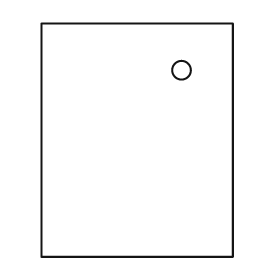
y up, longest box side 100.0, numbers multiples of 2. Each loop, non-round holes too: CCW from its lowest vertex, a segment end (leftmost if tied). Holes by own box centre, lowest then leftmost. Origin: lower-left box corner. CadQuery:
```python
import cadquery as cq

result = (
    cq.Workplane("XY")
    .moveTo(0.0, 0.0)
    .lineTo(82.0, 0.0)
    .lineTo(82.0, 100.0)
    .lineTo(0.0, 100.0)
    .close()
    .moveTo(60.0, 80.0)
    .circle(4.0)
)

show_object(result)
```